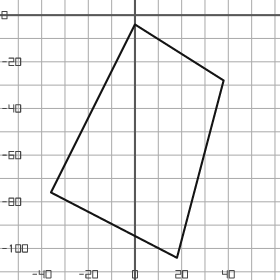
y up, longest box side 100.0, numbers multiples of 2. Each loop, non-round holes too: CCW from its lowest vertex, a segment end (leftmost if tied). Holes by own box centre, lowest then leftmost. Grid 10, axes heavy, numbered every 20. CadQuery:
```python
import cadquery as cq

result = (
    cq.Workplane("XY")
    .moveTo(18.0, -104.0)
    .lineTo(38.0, -28.0)
    .lineTo(0.0, -4.0)
    .lineTo(-36.0, -76.0)
    .close()
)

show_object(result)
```